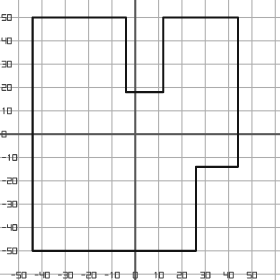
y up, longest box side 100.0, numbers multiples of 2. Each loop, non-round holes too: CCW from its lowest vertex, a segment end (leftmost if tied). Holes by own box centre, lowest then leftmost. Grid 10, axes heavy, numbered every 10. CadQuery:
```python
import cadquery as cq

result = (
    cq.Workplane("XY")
    .moveTo(-44.0, -50.0)
    .lineTo(26.0, -50.0)
    .lineTo(26.0, -14.0)
    .lineTo(44.0, -14.0)
    .lineTo(44.0, 50.0)
    .lineTo(12.0, 50.0)
    .lineTo(12.0, 18.0)
    .lineTo(-4.0, 18.0)
    .lineTo(-4.0, 50.0)
    .lineTo(-44.0, 50.0)
    .close()
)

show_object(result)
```